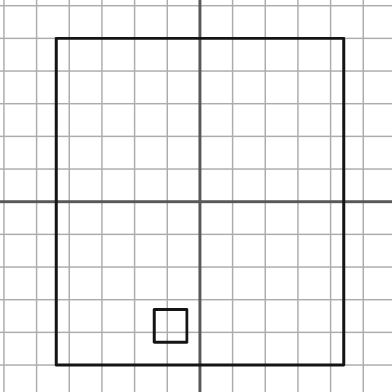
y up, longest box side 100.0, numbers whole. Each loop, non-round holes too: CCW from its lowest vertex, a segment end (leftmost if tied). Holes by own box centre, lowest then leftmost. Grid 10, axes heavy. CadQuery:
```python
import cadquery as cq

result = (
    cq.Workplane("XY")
    .moveTo(-44.0, -50.0)
    .lineTo(44.0, -50.0)
    .lineTo(44.0, 50.0)
    .lineTo(-44.0, 50.0)
    .close()
    .moveTo(-14.0, -43.0)
    .lineTo(-4.0, -43.0)
    .lineTo(-4.0, -33.0)
    .lineTo(-14.0, -33.0)
    .close()
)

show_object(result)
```